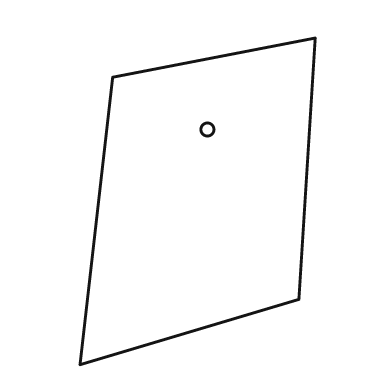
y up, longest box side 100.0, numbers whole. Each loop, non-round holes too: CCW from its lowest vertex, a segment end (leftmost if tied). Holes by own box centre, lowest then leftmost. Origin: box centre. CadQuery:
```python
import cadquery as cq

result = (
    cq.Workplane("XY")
    .moveTo(-36.0, -50.0)
    .lineTo(31.0, -30.0)
    .lineTo(36.0, 50.0)
    .lineTo(-26.0, 38.0)
    .close()
    .moveTo(3.0, 22.0)
    .circle(2.0)
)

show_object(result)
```